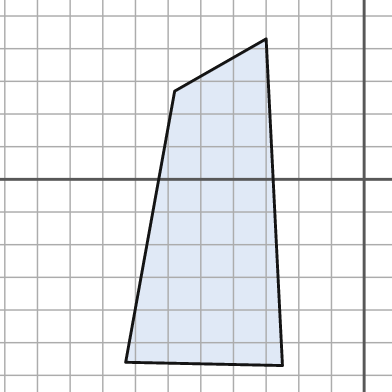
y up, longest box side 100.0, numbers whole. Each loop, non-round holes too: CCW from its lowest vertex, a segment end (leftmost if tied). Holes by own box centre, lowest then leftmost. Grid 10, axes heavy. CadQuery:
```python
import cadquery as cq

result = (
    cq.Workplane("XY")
    .moveTo(-25.0, -57.0)
    .lineTo(-30.0, 43.0)
    .lineTo(-58.0, 27.0)
    .lineTo(-73.0, -56.0)
    .close()
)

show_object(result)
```